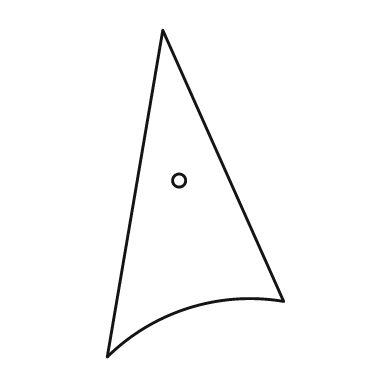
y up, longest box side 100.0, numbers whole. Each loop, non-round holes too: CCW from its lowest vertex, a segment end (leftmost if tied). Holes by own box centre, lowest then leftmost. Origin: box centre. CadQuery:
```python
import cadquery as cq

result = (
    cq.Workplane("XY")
    .moveTo(-27.0, -50.0)
    .threePointArc((-2.0, -35.0), (27.0, -33.0))
    .lineTo(-10.0, 50.0)
    .close()
    .moveTo(-5.0, 4.0)
    .circle(2.0)
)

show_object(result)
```